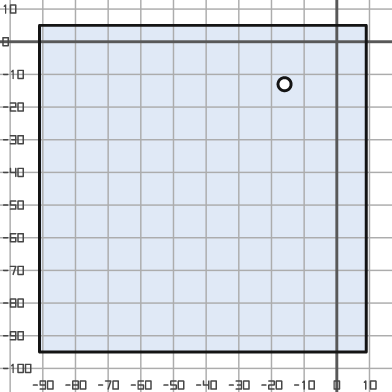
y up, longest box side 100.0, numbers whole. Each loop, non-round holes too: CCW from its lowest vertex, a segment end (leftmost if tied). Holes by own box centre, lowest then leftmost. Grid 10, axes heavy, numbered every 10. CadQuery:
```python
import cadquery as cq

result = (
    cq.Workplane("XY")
    .moveTo(-91.0, -95.0)
    .lineTo(9.0, -95.0)
    .lineTo(9.0, 5.0)
    .lineTo(-91.0, 5.0)
    .close()
    .moveTo(-16.0, -13.0)
    .circle(2.0)
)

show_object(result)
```